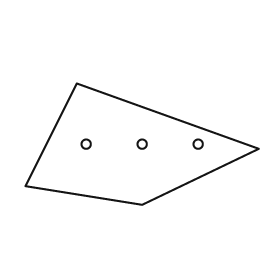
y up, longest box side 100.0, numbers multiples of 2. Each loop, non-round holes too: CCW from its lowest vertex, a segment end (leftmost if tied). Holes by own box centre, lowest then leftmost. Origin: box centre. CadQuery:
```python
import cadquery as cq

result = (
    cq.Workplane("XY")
    .moveTo(0.0, -26.0)
    .lineTo(50.0, -2.0)
    .lineTo(-28.0, 26.0)
    .lineTo(-50.0, -18.0)
    .close()
    .moveTo(-24.0, 0.0)
    .circle(2.0)
    .moveTo(0.0, 0.0)
    .circle(2.0)
    .moveTo(24.0, 0.0)
    .circle(2.0)
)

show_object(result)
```